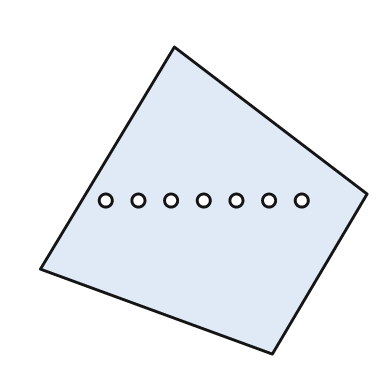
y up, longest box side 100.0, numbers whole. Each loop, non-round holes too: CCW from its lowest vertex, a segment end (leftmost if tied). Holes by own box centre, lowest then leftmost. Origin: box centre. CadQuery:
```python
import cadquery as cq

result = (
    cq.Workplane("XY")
    .moveTo(21.0, -47.0)
    .lineTo(50.0, 2.0)
    .lineTo(-9.0, 47.0)
    .lineTo(-50.0, -21.0)
    .close()
    .moveTo(-30.0, 0.0)
    .circle(2.0)
    .moveTo(-20.0, 0.0)
    .circle(2.0)
    .moveTo(-10.0, 0.0)
    .circle(2.0)
    .moveTo(0.0, 0.0)
    .circle(2.0)
    .moveTo(10.0, 0.0)
    .circle(2.0)
    .moveTo(20.0, 0.0)
    .circle(2.0)
    .moveTo(30.0, 0.0)
    .circle(2.0)
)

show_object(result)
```